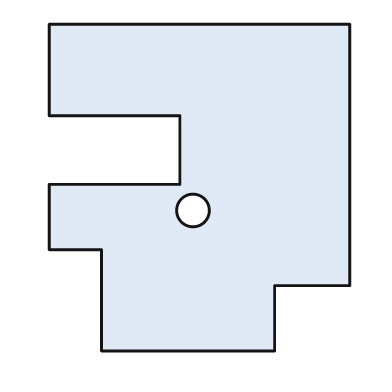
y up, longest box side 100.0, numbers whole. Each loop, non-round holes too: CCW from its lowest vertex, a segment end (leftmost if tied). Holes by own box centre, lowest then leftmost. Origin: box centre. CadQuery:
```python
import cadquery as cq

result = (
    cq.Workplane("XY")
    .moveTo(-30.0, -50.0)
    .lineTo(23.0, -50.0)
    .lineTo(23.0, -30.0)
    .lineTo(46.0, -30.0)
    .lineTo(46.0, 50.0)
    .lineTo(-46.0, 50.0)
    .lineTo(-46.0, 22.0)
    .lineTo(-6.0, 22.0)
    .lineTo(-6.0, 1.0)
    .lineTo(-46.0, 1.0)
    .lineTo(-46.0, -19.0)
    .lineTo(-30.0, -19.0)
    .close()
    .moveTo(-2.0, -7.0)
    .circle(5.0)
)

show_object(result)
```